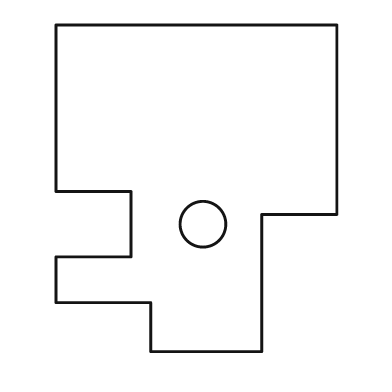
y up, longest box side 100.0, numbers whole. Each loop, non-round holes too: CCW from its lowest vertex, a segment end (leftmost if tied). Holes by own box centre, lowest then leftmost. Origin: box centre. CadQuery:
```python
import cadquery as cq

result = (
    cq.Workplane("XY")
    .moveTo(-14.0, -50.0)
    .lineTo(20.0, -50.0)
    .lineTo(20.0, -8.0)
    .lineTo(43.0, -8.0)
    .lineTo(43.0, 50.0)
    .lineTo(-43.0, 50.0)
    .lineTo(-43.0, -1.0)
    .lineTo(-20.0, -1.0)
    .lineTo(-20.0, -21.0)
    .lineTo(-43.0, -21.0)
    .lineTo(-43.0, -35.0)
    .lineTo(-14.0, -35.0)
    .close()
    .moveTo(2.0, -11.0)
    .circle(7.0)
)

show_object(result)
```